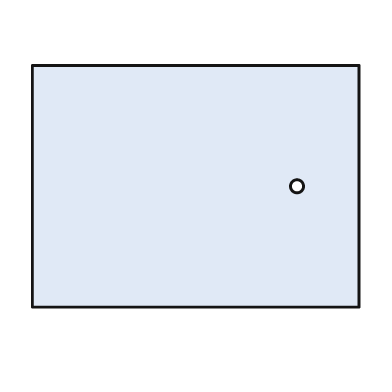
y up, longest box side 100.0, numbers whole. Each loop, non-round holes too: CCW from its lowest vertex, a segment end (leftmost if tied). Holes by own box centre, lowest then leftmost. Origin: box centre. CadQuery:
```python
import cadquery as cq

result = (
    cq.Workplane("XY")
    .moveTo(-50.0, -37.0)
    .lineTo(50.0, -37.0)
    .lineTo(50.0, 37.0)
    .lineTo(-50.0, 37.0)
    .close()
    .moveTo(31.0, 0.0)
    .circle(2.0)
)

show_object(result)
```